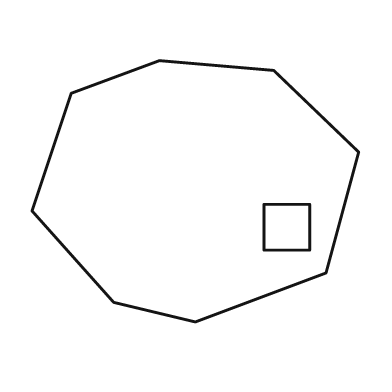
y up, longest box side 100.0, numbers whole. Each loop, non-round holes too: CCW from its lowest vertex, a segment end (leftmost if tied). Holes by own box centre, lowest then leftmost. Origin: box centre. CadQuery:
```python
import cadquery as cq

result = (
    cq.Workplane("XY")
    .moveTo(0.0, -40.0)
    .lineTo(40.0, -25.0)
    .lineTo(50.0, 12.0)
    .lineTo(24.0, 37.0)
    .lineTo(-11.0, 40.0)
    .lineTo(-38.0, 30.0)
    .lineTo(-50.0, -6.0)
    .lineTo(-25.0, -34.0)
    .close()
    .moveTo(21.0, -18.0)
    .lineTo(35.0, -18.0)
    .lineTo(35.0, -4.0)
    .lineTo(21.0, -4.0)
    .close()
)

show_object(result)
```